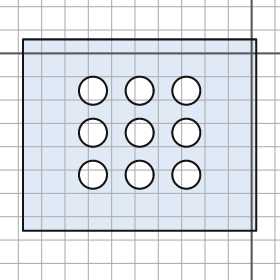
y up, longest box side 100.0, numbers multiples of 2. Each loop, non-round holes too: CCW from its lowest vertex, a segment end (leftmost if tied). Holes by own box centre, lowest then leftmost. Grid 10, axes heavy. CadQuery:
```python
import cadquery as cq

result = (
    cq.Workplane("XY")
    .moveTo(-98.0, -76.0)
    .lineTo(2.0, -76.0)
    .lineTo(2.0, 6.0)
    .lineTo(-98.0, 6.0)
    .close()
    .moveTo(-68.0, -52.0)
    .circle(6.0)
    .moveTo(-48.0, -52.0)
    .circle(6.0)
    .moveTo(-28.0, -52.0)
    .circle(6.0)
    .moveTo(-68.0, -34.0)
    .circle(6.0)
    .moveTo(-48.0, -34.0)
    .circle(6.0)
    .moveTo(-28.0, -34.0)
    .circle(6.0)
    .moveTo(-68.0, -16.0)
    .circle(6.0)
    .moveTo(-48.0, -16.0)
    .circle(6.0)
    .moveTo(-28.0, -16.0)
    .circle(6.0)
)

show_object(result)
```